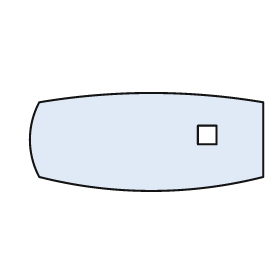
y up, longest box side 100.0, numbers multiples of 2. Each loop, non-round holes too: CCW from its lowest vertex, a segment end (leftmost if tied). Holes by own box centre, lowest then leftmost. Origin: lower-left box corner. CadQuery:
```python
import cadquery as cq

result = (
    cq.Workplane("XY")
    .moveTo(4.0, 6.0)
    .threePointArc((52.0, 0.0), (100.0, 6.0))
    .lineTo(100.0, 38.0)
    .threePointArc((52.0, 42.0), (4.0, 38.0))
    .threePointArc((0.0, 22.0), (4.0, 6.0))
    .close()
    .moveTo(72.0, 20.0)
    .lineTo(80.0, 20.0)
    .lineTo(80.0, 28.0)
    .lineTo(72.0, 28.0)
    .close()
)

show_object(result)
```